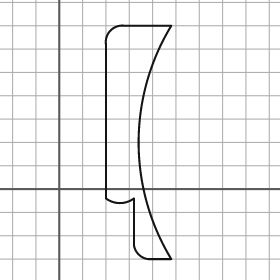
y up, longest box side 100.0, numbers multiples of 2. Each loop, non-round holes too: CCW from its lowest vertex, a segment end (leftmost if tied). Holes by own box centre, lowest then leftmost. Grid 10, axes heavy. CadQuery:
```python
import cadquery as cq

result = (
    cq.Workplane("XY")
    .moveTo(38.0, -30.0)
    .lineTo(48.0, -30.0)
    .threePointArc((34.0, 20.0), (48.0, 70.0))
    .lineTo(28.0, 70.0)
    .threePointArc((22.0, 68.0), (20.0, 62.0))
    .lineTo(20.0, -4.0)
    .threePointArc((26.0, -6.0), (32.0, -4.0))
    .lineTo(32.0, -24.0)
    .threePointArc((34.0, -28.0), (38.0, -30.0))
    .close()
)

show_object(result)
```